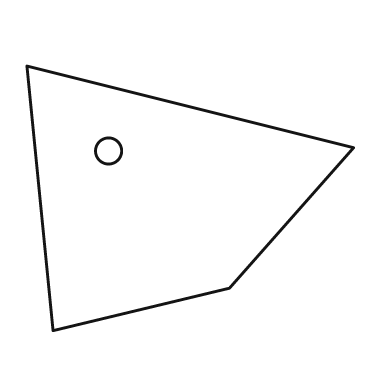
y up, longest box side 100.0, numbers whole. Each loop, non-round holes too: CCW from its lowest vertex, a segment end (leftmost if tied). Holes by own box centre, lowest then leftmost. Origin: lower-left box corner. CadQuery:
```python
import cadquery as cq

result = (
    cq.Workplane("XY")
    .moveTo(8.0, 0.0)
    .lineTo(62.0, 13.0)
    .lineTo(100.0, 56.0)
    .lineTo(0.0, 81.0)
    .close()
    .moveTo(25.0, 55.0)
    .circle(4.0)
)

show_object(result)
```